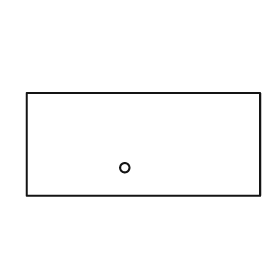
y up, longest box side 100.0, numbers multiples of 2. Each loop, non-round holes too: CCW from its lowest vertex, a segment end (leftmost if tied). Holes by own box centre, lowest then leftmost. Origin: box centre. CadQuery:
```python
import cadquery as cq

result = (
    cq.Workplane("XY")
    .moveTo(-50.0, -22.0)
    .lineTo(50.0, -22.0)
    .lineTo(50.0, 22.0)
    .lineTo(-50.0, 22.0)
    .close()
    .moveTo(-8.0, -10.0)
    .circle(2.0)
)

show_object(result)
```